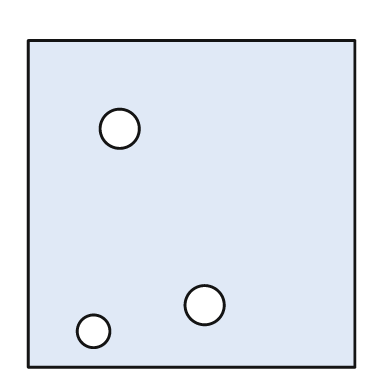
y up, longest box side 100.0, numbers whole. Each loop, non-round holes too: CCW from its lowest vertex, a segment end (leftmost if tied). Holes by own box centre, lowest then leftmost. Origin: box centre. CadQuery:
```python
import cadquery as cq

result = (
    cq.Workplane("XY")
    .moveTo(-50.0, -50.0)
    .lineTo(50.0, -50.0)
    .lineTo(50.0, 50.0)
    .lineTo(-50.0, 50.0)
    .close()
    .moveTo(-30.0, -39.0)
    .circle(5.0)
    .moveTo(4.0, -31.0)
    .circle(6.0)
    .moveTo(-22.0, 23.0)
    .circle(6.0)
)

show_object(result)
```